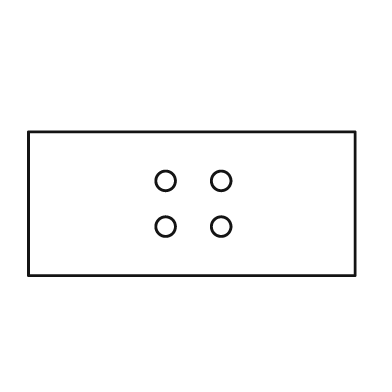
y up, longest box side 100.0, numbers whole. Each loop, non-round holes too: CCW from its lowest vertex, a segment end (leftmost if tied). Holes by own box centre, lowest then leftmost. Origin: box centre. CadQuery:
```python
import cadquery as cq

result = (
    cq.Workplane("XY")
    .moveTo(-50.0, -22.0)
    .lineTo(50.0, -22.0)
    .lineTo(50.0, 22.0)
    .lineTo(-50.0, 22.0)
    .close()
    .moveTo(-8.0, -7.0)
    .circle(3.0)
    .moveTo(9.0, -7.0)
    .circle(3.0)
    .moveTo(-8.0, 7.0)
    .circle(3.0)
    .moveTo(9.0, 7.0)
    .circle(3.0)
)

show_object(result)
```